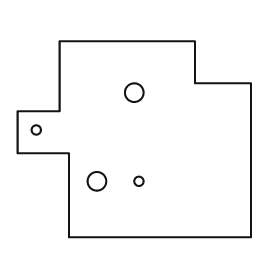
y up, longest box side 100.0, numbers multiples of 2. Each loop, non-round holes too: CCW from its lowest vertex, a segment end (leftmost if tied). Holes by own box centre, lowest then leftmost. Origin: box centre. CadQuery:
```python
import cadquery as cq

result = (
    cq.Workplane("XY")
    .moveTo(-28.0, -42.0)
    .lineTo(50.0, -42.0)
    .lineTo(50.0, 24.0)
    .lineTo(26.0, 24.0)
    .lineTo(26.0, 42.0)
    .lineTo(-32.0, 42.0)
    .lineTo(-32.0, 12.0)
    .lineTo(-50.0, 12.0)
    .lineTo(-50.0, -6.0)
    .lineTo(-28.0, -6.0)
    .close()
    .moveTo(-16.0, -18.0)
    .circle(4.0)
    .moveTo(2.0, -18.0)
    .circle(2.0)
    .moveTo(-42.0, 4.0)
    .circle(2.0)
    .moveTo(0.0, 20.0)
    .circle(4.0)
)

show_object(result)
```